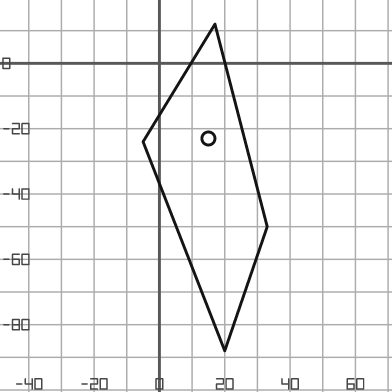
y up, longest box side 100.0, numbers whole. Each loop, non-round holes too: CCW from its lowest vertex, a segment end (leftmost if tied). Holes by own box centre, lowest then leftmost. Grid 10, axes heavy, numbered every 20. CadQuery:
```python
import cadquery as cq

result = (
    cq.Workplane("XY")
    .moveTo(20.0, -88.0)
    .lineTo(33.0, -50.0)
    .lineTo(17.0, 12.0)
    .lineTo(-5.0, -24.0)
    .close()
    .moveTo(15.0, -23.0)
    .circle(2.0)
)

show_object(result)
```